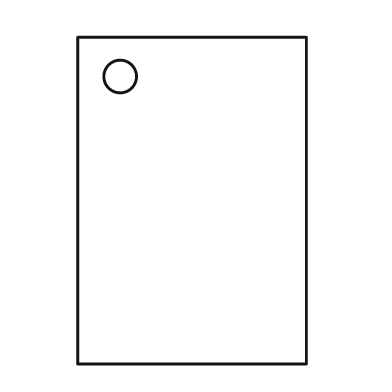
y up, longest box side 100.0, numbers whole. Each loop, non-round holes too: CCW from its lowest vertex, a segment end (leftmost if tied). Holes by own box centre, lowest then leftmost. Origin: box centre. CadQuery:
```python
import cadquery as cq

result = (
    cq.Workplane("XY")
    .moveTo(-35.0, -50.0)
    .lineTo(35.0, -50.0)
    .lineTo(35.0, 50.0)
    .lineTo(-35.0, 50.0)
    .close()
    .moveTo(-22.0, 38.0)
    .circle(5.0)
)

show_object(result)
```